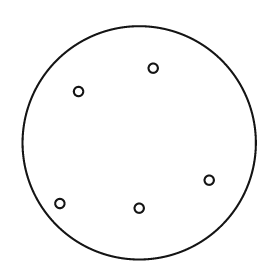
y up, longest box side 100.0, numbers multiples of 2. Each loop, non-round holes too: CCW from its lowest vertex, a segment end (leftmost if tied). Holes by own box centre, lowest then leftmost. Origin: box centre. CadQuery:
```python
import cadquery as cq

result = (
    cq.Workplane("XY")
    .moveTo(0.0, 0.0)
    .circle(50.0)
    .moveTo(0.0, -28.0)
    .circle(2.0)
    .moveTo(-34.0, -26.0)
    .circle(2.0)
    .moveTo(30.0, -16.0)
    .circle(2.0)
    .moveTo(-26.0, 22.0)
    .circle(2.0)
    .moveTo(6.0, 32.0)
    .circle(2.0)
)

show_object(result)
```